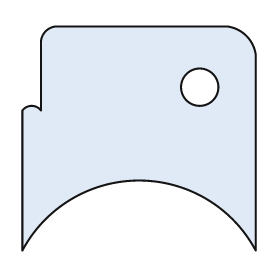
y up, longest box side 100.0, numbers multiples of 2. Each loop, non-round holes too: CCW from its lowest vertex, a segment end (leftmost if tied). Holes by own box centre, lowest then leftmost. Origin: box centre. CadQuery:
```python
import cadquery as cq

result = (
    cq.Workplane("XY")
    .moveTo(-50.0, -48.0)
    .threePointArc((0.0, -18.0), (50.0, -48.0))
    .lineTo(50.0, 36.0)
    .threePointArc((46.0, 44.0), (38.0, 48.0))
    .lineTo(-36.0, 48.0)
    .threePointArc((-40.0, 46.0), (-42.0, 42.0))
    .lineTo(-42.0, 12.0)
    .threePointArc((-46.0, 14.0), (-50.0, 12.0))
    .close()
    .moveTo(26.0, 22.0)
    .circle(8.0)
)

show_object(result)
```